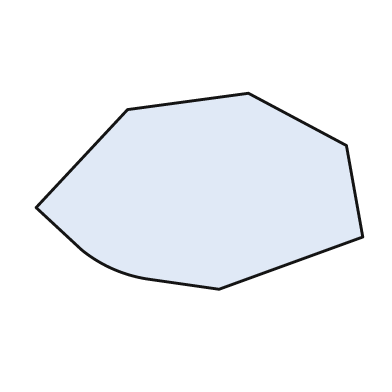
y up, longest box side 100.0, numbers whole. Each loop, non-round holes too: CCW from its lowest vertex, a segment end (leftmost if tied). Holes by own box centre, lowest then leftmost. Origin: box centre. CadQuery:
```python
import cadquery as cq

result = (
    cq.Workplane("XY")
    .moveTo(6.0, -30.0)
    .lineTo(50.0, -14.0)
    .lineTo(45.0, 14.0)
    .lineTo(15.0, 30.0)
    .lineTo(-22.0, 25.0)
    .lineTo(-50.0, -5.0)
    .lineTo(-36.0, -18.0)
    .threePointArc((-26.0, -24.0), (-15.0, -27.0))
    .close()
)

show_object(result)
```